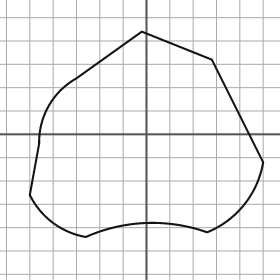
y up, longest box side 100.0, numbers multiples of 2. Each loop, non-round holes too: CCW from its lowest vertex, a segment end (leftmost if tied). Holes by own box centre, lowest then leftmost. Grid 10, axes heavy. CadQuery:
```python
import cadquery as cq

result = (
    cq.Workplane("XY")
    .moveTo(-26.0, -44.0)
    .threePointArc((0.0, -38.0), (26.0, -42.0))
    .threePointArc((42.0, -30.0), (50.0, -12.0))
    .lineTo(28.0, 32.0)
    .lineTo(-2.0, 44.0)
    .lineTo(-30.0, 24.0)
    .threePointArc((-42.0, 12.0), (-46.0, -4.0))
    .lineTo(-50.0, -26.0)
    .threePointArc((-40.0, -38.0), (-26.0, -44.0))
    .close()
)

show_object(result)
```